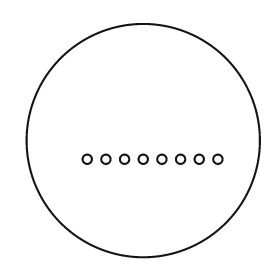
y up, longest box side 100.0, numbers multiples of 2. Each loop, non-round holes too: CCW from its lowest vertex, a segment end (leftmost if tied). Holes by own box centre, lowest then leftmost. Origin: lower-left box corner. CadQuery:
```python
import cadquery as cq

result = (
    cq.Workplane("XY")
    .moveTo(50.0, 50.0)
    .circle(50.0)
    .moveTo(26.0, 42.0)
    .circle(2.0)
    .moveTo(34.0, 42.0)
    .circle(2.0)
    .moveTo(42.0, 42.0)
    .circle(2.0)
    .moveTo(50.0, 42.0)
    .circle(2.0)
    .moveTo(58.0, 42.0)
    .circle(2.0)
    .moveTo(66.0, 42.0)
    .circle(2.0)
    .moveTo(74.0, 42.0)
    .circle(2.0)
    .moveTo(82.0, 42.0)
    .circle(2.0)
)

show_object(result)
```